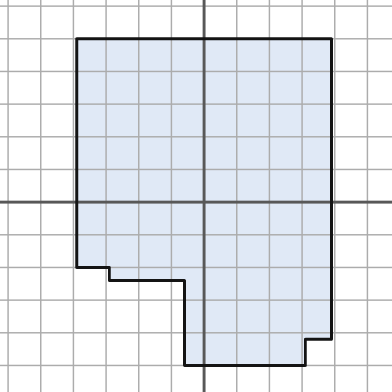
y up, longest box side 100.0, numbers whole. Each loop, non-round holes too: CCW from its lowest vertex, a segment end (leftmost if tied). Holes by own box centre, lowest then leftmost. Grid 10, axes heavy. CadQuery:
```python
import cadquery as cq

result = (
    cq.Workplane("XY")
    .moveTo(-6.0, -50.0)
    .lineTo(31.0, -50.0)
    .lineTo(31.0, -42.0)
    .lineTo(39.0, -42.0)
    .lineTo(39.0, 50.0)
    .lineTo(-39.0, 50.0)
    .lineTo(-39.0, -20.0)
    .lineTo(-29.0, -20.0)
    .lineTo(-29.0, -24.0)
    .lineTo(-6.0, -24.0)
    .close()
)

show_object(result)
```